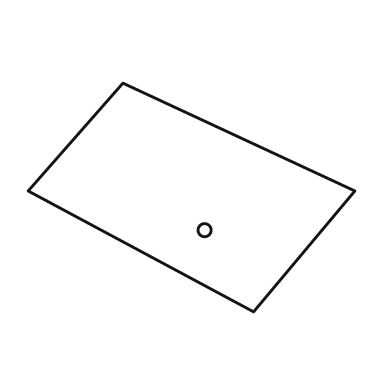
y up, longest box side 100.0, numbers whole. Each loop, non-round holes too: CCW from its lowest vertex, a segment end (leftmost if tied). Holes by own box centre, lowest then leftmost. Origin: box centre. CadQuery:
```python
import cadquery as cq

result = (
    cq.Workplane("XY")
    .moveTo(19.0, -35.0)
    .lineTo(50.0, 2.0)
    .lineTo(-21.0, 35.0)
    .lineTo(-50.0, 2.0)
    .close()
    .moveTo(4.0, -10.0)
    .circle(2.0)
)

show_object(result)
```